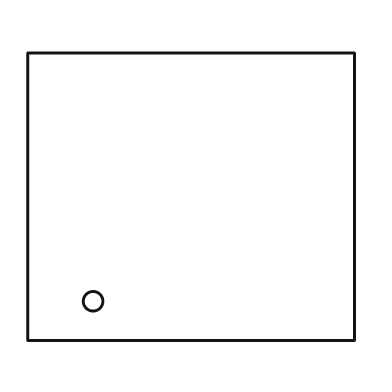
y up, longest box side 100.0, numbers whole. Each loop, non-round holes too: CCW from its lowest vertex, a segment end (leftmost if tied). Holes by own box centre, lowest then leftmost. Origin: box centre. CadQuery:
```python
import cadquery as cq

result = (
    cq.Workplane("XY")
    .moveTo(-50.0, -44.0)
    .lineTo(50.0, -44.0)
    .lineTo(50.0, 44.0)
    .lineTo(-50.0, 44.0)
    .close()
    .moveTo(-30.0, -32.0)
    .circle(3.0)
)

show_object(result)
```